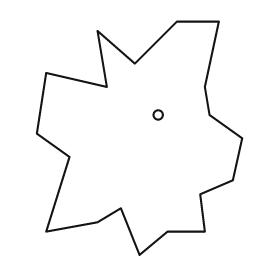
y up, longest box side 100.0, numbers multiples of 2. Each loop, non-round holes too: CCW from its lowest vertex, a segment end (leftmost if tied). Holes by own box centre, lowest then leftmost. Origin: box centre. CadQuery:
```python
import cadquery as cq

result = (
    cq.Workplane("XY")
    .moveTo(0.0, -50.0)
    .lineTo(12.0, -40.0)
    .lineTo(28.0, -40.0)
    .lineTo(26.0, -24.0)
    .lineTo(40.0, -18.0)
    .lineTo(44.0, 0.0)
    .lineTo(30.0, 10.0)
    .lineTo(28.0, 22.0)
    .lineTo(34.0, 50.0)
    .lineTo(16.0, 50.0)
    .lineTo(-2.0, 32.0)
    .lineTo(-18.0, 46.0)
    .lineTo(-14.0, 22.0)
    .lineTo(-40.0, 28.0)
    .lineTo(-44.0, 2.0)
    .lineTo(-30.0, -8.0)
    .lineTo(-40.0, -40.0)
    .lineTo(-18.0, -36.0)
    .lineTo(-8.0, -30.0)
    .close()
    .moveTo(8.0, 10.0)
    .circle(2.0)
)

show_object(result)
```